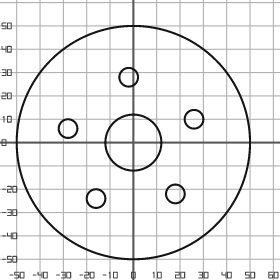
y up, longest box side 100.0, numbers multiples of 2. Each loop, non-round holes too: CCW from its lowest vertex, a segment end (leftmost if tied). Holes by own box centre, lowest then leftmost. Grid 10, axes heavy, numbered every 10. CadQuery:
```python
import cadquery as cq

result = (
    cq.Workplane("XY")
    .moveTo(0.0, 0.0)
    .circle(50.0)
    .moveTo(-16.0, -24.0)
    .circle(4.0)
    .moveTo(18.0, -22.0)
    .circle(4.0)
    .moveTo(0.0, 0.0)
    .circle(12.0)
    .moveTo(-28.0, 6.0)
    .circle(4.0)
    .moveTo(26.0, 10.0)
    .circle(4.0)
    .moveTo(-2.0, 28.0)
    .circle(4.0)
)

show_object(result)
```